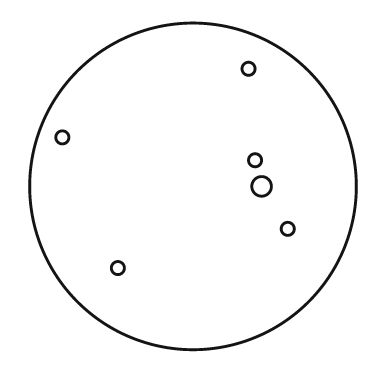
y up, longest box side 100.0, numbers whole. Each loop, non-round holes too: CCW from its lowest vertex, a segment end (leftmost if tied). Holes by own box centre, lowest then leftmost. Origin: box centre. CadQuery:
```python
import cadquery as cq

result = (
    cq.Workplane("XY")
    .moveTo(0.0, 0.0)
    .circle(50.0)
    .moveTo(-23.0, -25.0)
    .circle(2.0)
    .moveTo(29.0, -13.0)
    .circle(2.0)
    .moveTo(21.0, 0.0)
    .circle(3.0)
    .moveTo(19.0, 8.0)
    .circle(2.0)
    .moveTo(-40.0, 15.0)
    .circle(2.0)
    .moveTo(17.0, 36.0)
    .circle(2.0)
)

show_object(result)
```